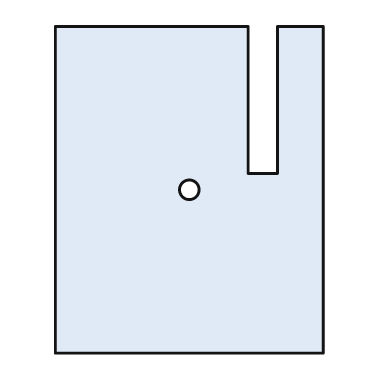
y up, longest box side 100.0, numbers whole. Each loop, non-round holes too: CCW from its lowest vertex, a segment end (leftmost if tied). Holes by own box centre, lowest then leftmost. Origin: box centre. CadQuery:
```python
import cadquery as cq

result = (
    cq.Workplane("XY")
    .moveTo(-41.0, -50.0)
    .lineTo(41.0, -50.0)
    .lineTo(41.0, 50.0)
    .lineTo(27.0, 50.0)
    .lineTo(27.0, 5.0)
    .lineTo(18.0, 5.0)
    .lineTo(18.0, 50.0)
    .lineTo(-41.0, 50.0)
    .close()
    .moveTo(0.0, 0.0)
    .circle(3.0)
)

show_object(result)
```